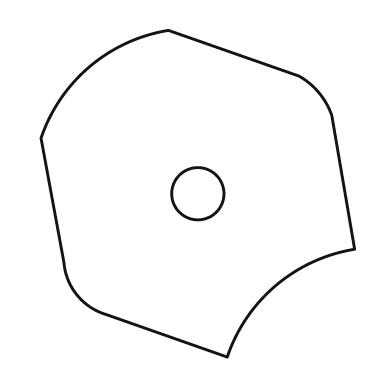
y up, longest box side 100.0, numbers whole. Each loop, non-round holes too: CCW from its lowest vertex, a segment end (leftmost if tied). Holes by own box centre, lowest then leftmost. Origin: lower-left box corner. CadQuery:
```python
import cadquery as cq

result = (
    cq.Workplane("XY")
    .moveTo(57.0, 0.0)
    .threePointArc((72.0, 22.0), (96.0, 33.0))
    .lineTo(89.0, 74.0)
    .threePointArc((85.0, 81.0), (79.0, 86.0))
    .lineTo(39.0, 100.0)
    .threePointArc((15.0, 89.0), (0.0, 67.0))
    .lineTo(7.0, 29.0)
    .threePointArc((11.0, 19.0), (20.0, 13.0))
    .close()
    .moveTo(48.0, 50.0)
    .circle(8.0)
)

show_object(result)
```